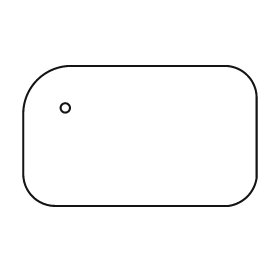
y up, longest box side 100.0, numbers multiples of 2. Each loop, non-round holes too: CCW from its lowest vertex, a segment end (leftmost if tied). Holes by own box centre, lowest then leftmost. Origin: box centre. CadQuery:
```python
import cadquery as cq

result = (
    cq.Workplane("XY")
    .moveTo(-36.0, -30.0)
    .lineTo(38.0, -30.0)
    .threePointArc((46.0, -26.0), (50.0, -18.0))
    .lineTo(50.0, 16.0)
    .threePointArc((46.0, 26.0), (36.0, 30.0))
    .lineTo(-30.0, 30.0)
    .threePointArc((-44.0, 24.0), (-50.0, 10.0))
    .lineTo(-50.0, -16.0)
    .threePointArc((-46.0, -26.0), (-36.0, -30.0))
    .close()
    .moveTo(-32.0, 12.0)
    .circle(2.0)
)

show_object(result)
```